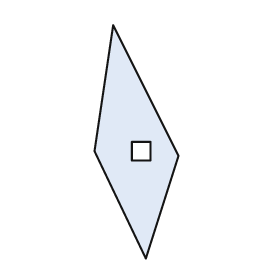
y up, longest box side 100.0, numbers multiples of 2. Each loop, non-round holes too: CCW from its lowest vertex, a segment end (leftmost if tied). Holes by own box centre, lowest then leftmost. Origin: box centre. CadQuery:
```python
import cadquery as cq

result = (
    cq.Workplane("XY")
    .moveTo(4.0, -50.0)
    .lineTo(18.0, -6.0)
    .lineTo(-10.0, 50.0)
    .lineTo(-18.0, -4.0)
    .close()
    .moveTo(-2.0, -8.0)
    .lineTo(6.0, -8.0)
    .lineTo(6.0, 0.0)
    .lineTo(-2.0, 0.0)
    .close()
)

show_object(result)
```